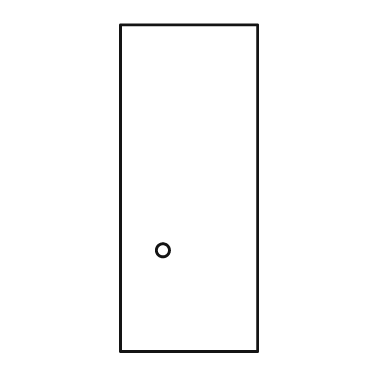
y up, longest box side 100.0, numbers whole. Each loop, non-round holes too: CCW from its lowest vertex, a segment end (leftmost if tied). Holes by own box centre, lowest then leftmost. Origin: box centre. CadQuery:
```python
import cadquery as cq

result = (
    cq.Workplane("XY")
    .moveTo(-21.0, -50.0)
    .lineTo(21.0, -50.0)
    .lineTo(21.0, 50.0)
    .lineTo(-21.0, 50.0)
    .close()
    .moveTo(-8.0, -19.0)
    .circle(2.0)
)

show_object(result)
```